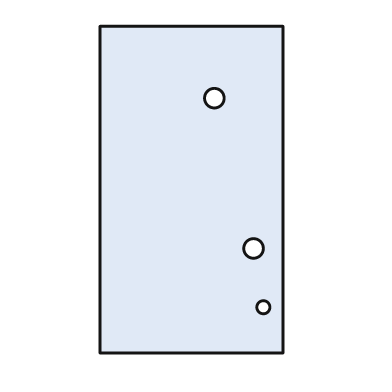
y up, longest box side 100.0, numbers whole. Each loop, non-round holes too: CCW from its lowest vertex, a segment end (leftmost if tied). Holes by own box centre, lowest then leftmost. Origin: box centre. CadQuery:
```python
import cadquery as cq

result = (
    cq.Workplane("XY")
    .moveTo(-28.0, -50.0)
    .lineTo(28.0, -50.0)
    .lineTo(28.0, 50.0)
    .lineTo(-28.0, 50.0)
    .close()
    .moveTo(22.0, -36.0)
    .circle(2.0)
    .moveTo(19.0, -18.0)
    .circle(3.0)
    .moveTo(7.0, 28.0)
    .circle(3.0)
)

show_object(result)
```